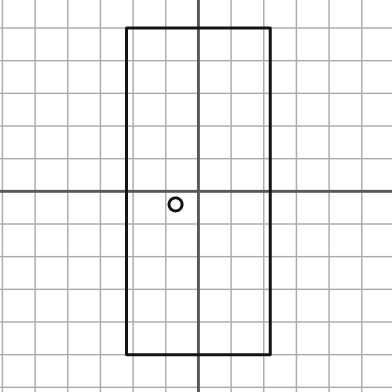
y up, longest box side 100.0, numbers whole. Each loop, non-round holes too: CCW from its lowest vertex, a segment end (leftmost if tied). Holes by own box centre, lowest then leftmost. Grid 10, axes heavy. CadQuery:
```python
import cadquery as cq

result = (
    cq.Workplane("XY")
    .moveTo(-22.0, -50.0)
    .lineTo(22.0, -50.0)
    .lineTo(22.0, 50.0)
    .lineTo(-22.0, 50.0)
    .close()
    .moveTo(-7.0, -4.0)
    .circle(2.0)
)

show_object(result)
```